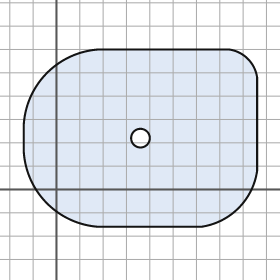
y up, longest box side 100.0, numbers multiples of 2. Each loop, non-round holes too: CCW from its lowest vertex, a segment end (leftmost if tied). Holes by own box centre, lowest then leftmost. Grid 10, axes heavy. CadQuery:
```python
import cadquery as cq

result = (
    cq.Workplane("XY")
    .moveTo(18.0, -16.0)
    .lineTo(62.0, -16.0)
    .threePointArc((78.0, -8.0), (86.0, 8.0))
    .lineTo(86.0, 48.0)
    .threePointArc((82.0, 56.0), (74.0, 60.0))
    .lineTo(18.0, 60.0)
    .threePointArc((-4.0, 50.0), (-14.0, 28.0))
    .lineTo(-14.0, 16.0)
    .threePointArc((-4.0, -6.0), (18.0, -16.0))
    .close()
    .moveTo(36.0, 22.0)
    .circle(4.0)
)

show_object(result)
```